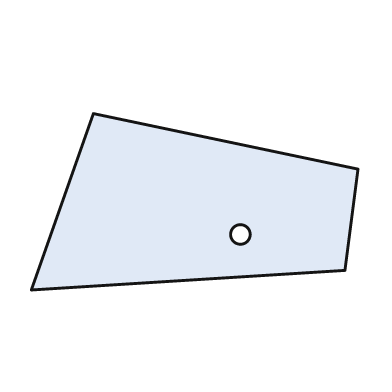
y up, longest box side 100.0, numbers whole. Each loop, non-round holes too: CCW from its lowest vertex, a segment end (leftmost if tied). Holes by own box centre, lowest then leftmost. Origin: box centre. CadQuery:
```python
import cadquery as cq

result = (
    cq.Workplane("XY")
    .moveTo(-50.0, -27.0)
    .lineTo(46.0, -21.0)
    .lineTo(50.0, 10.0)
    .lineTo(-31.0, 27.0)
    .close()
    .moveTo(14.0, -10.0)
    .circle(3.0)
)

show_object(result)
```